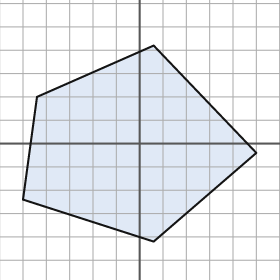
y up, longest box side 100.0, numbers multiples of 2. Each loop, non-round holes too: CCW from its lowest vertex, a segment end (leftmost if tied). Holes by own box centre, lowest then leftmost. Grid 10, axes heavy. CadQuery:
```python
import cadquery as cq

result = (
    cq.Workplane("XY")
    .moveTo(6.0, -42.0)
    .lineTo(50.0, -4.0)
    .lineTo(6.0, 42.0)
    .lineTo(-44.0, 20.0)
    .lineTo(-50.0, -24.0)
    .close()
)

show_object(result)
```